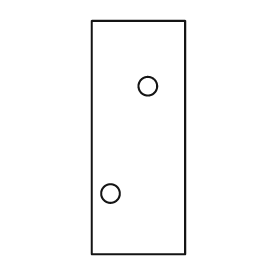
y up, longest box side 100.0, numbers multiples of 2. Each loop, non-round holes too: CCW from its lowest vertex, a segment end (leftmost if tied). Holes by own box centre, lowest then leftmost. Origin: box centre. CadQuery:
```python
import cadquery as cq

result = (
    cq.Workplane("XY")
    .moveTo(-20.0, -50.0)
    .lineTo(20.0, -50.0)
    .lineTo(20.0, 50.0)
    .lineTo(-20.0, 50.0)
    .close()
    .moveTo(-12.0, -24.0)
    .circle(4.0)
    .moveTo(4.0, 22.0)
    .circle(4.0)
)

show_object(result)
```